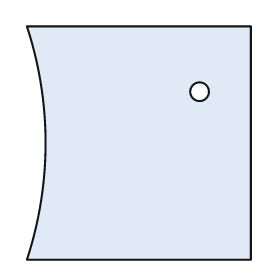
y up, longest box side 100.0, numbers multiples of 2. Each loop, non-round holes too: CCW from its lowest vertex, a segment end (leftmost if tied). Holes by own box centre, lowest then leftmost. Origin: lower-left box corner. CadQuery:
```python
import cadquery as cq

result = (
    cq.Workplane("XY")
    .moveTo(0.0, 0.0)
    .lineTo(96.0, 0.0)
    .lineTo(96.0, 100.0)
    .lineTo(0.0, 100.0)
    .threePointArc((8.0, 50.0), (0.0, 0.0))
    .close()
    .moveTo(74.0, 72.0)
    .circle(4.0)
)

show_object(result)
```